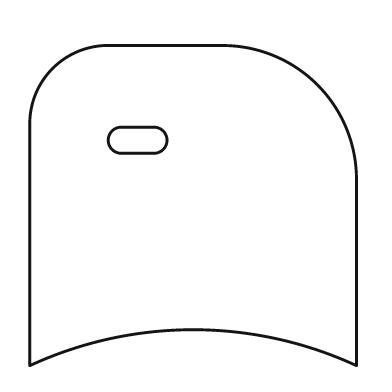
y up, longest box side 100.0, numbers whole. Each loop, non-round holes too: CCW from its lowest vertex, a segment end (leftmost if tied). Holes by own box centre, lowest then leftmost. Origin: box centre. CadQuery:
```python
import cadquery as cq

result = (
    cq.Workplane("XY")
    .moveTo(-50.0, -49.0)
    .threePointArc((0.0, -38.0), (50.0, -49.0))
    .lineTo(50.0, 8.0)
    .threePointArc((38.0, 37.0), (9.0, 49.0))
    .lineTo(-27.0, 49.0)
    .threePointArc((-43.0, 42.0), (-50.0, 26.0))
    .close()
    .moveTo(-22.0, 16.0)
    .lineTo(-12.0, 16.0)
    .threePointArc((-8.0, 20.0), (-12.0, 24.0))
    .lineTo(-22.0, 24.0)
    .threePointArc((-26.0, 20.0), (-22.0, 16.0))
    .close()
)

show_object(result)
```